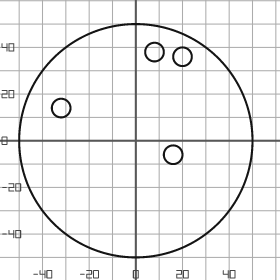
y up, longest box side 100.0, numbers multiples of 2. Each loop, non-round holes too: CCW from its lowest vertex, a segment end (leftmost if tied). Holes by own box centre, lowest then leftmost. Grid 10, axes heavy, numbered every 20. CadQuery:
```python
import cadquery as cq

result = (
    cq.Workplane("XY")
    .moveTo(0.0, 0.0)
    .circle(50.0)
    .moveTo(16.0, -6.0)
    .circle(4.0)
    .moveTo(-32.0, 14.0)
    .circle(4.0)
    .moveTo(20.0, 36.0)
    .circle(4.0)
    .moveTo(8.0, 38.0)
    .circle(4.0)
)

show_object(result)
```